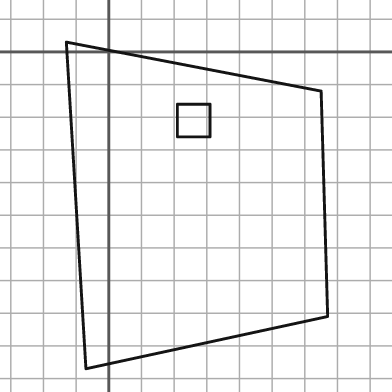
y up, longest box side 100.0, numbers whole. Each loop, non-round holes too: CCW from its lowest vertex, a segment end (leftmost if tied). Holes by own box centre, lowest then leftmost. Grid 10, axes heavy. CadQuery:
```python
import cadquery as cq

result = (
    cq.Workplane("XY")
    .moveTo(-7.0, -97.0)
    .lineTo(67.0, -81.0)
    .lineTo(65.0, -12.0)
    .lineTo(-13.0, 3.0)
    .close()
    .moveTo(21.0, -26.0)
    .lineTo(31.0, -26.0)
    .lineTo(31.0, -16.0)
    .lineTo(21.0, -16.0)
    .close()
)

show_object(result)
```